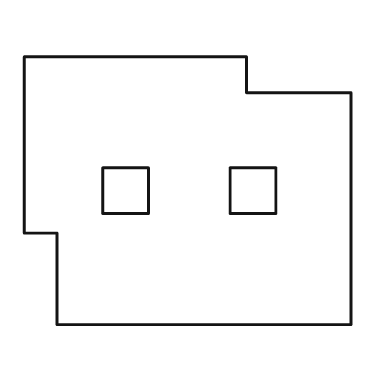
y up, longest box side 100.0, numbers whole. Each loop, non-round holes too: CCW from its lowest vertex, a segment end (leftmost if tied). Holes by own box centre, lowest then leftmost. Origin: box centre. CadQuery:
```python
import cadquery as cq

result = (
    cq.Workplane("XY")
    .moveTo(-40.0, -41.0)
    .lineTo(50.0, -41.0)
    .lineTo(50.0, 30.0)
    .lineTo(18.0, 30.0)
    .lineTo(18.0, 41.0)
    .lineTo(-50.0, 41.0)
    .lineTo(-50.0, -13.0)
    .lineTo(-40.0, -13.0)
    .close()
    .moveTo(-26.0, -7.0)
    .lineTo(-12.0, -7.0)
    .lineTo(-12.0, 7.0)
    .lineTo(-26.0, 7.0)
    .close()
    .moveTo(13.0, -7.0)
    .lineTo(27.0, -7.0)
    .lineTo(27.0, 7.0)
    .lineTo(13.0, 7.0)
    .close()
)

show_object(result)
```